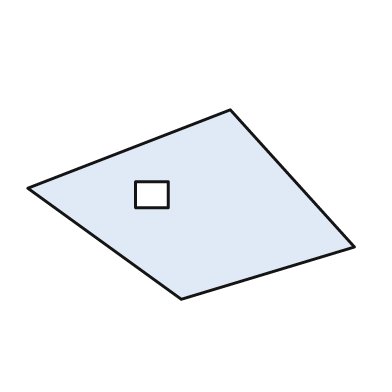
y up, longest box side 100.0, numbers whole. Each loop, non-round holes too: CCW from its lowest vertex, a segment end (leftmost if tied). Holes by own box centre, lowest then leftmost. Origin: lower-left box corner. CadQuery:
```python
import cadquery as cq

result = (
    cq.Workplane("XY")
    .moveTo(47.0, 0.0)
    .lineTo(100.0, 16.0)
    .lineTo(62.0, 58.0)
    .lineTo(0.0, 34.0)
    .close()
    .moveTo(33.0, 28.0)
    .lineTo(43.0, 28.0)
    .lineTo(43.0, 36.0)
    .lineTo(33.0, 36.0)
    .close()
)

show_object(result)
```